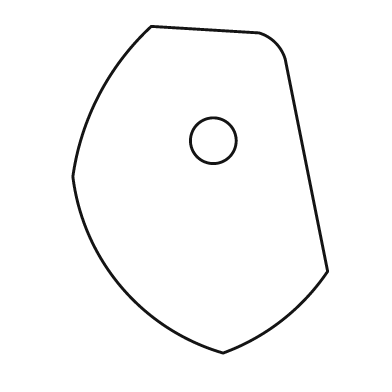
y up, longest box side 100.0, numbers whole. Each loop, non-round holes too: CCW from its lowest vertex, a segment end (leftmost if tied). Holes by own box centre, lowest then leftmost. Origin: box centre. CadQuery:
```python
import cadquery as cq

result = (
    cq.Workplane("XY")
    .moveTo(7.0, -50.0)
    .threePointArc((25.0, -40.0), (39.0, -25.0))
    .lineTo(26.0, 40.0)
    .threePointArc((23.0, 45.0), (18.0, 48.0))
    .lineTo(-15.0, 50.0)
    .threePointArc((-31.0, 29.0), (-39.0, 4.0))
    .threePointArc((-24.0, -30.0), (7.0, -50.0))
    .close()
    .moveTo(4.0, 15.0)
    .circle(7.0)
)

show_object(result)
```